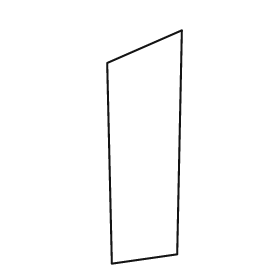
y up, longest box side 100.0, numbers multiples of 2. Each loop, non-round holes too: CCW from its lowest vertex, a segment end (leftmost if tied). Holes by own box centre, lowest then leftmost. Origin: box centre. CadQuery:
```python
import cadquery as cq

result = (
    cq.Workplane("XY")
    .moveTo(-14.0, -50.0)
    .lineTo(14.0, -46.0)
    .lineTo(16.0, 50.0)
    .lineTo(-16.0, 36.0)
    .close()
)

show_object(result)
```